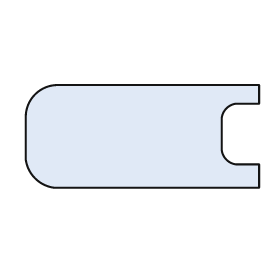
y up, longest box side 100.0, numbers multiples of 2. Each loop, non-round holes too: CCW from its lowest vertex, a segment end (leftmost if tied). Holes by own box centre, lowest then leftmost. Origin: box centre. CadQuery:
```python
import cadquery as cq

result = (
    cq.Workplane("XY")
    .moveTo(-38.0, -22.0)
    .lineTo(50.0, -22.0)
    .lineTo(50.0, -12.0)
    .lineTo(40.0, -12.0)
    .threePointArc((36.0, -10.0), (34.0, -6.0))
    .lineTo(34.0, 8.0)
    .threePointArc((36.0, 12.0), (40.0, 14.0))
    .lineTo(50.0, 14.0)
    .lineTo(50.0, 22.0)
    .lineTo(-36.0, 22.0)
    .threePointArc((-46.0, 18.0), (-50.0, 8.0))
    .lineTo(-50.0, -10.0)
    .threePointArc((-46.0, -18.0), (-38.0, -22.0))
    .close()
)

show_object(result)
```